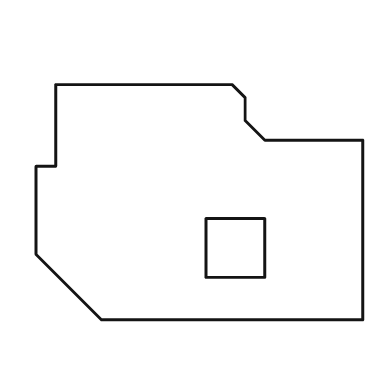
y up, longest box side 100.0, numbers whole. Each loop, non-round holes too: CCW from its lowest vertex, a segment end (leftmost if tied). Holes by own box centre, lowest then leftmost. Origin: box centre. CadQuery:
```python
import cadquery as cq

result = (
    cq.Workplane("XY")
    .moveTo(-30.0, -36.0)
    .lineTo(50.0, -36.0)
    .lineTo(50.0, 19.0)
    .lineTo(20.0, 19.0)
    .lineTo(14.0, 25.0)
    .lineTo(14.0, 32.0)
    .lineTo(10.0, 36.0)
    .lineTo(-44.0, 36.0)
    .lineTo(-44.0, 11.0)
    .lineTo(-50.0, 11.0)
    .lineTo(-50.0, -16.0)
    .close()
    .moveTo(2.0, -23.0)
    .lineTo(20.0, -23.0)
    .lineTo(20.0, -5.0)
    .lineTo(2.0, -5.0)
    .close()
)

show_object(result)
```